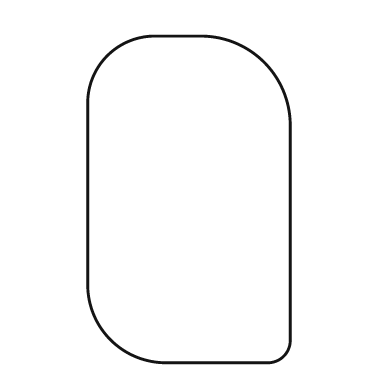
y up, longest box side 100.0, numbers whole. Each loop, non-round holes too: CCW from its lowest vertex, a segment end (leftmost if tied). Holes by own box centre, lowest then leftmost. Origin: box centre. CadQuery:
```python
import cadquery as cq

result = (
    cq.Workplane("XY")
    .moveTo(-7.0, -50.0)
    .lineTo(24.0, -50.0)
    .threePointArc((29.0, -48.0), (31.0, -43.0))
    .lineTo(31.0, 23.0)
    .threePointArc((23.0, 42.0), (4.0, 50.0))
    .lineTo(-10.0, 50.0)
    .threePointArc((-25.0, 44.0), (-31.0, 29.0))
    .lineTo(-31.0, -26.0)
    .threePointArc((-24.0, -43.0), (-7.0, -50.0))
    .close()
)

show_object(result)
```